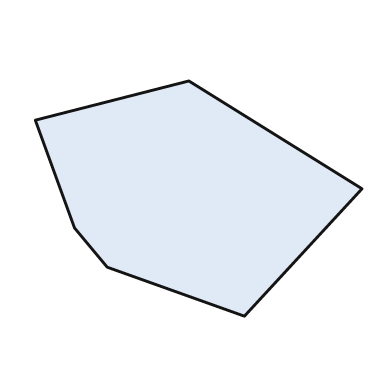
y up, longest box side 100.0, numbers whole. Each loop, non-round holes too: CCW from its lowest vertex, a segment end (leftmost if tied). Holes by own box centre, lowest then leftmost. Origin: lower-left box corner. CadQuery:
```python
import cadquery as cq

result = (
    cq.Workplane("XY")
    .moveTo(64.0, 0.0)
    .lineTo(100.0, 39.0)
    .lineTo(47.0, 72.0)
    .lineTo(0.0, 60.0)
    .lineTo(12.0, 27.0)
    .lineTo(22.0, 15.0)
    .close()
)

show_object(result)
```